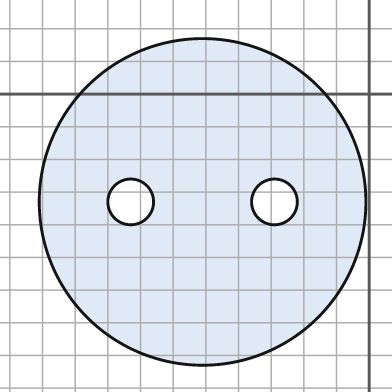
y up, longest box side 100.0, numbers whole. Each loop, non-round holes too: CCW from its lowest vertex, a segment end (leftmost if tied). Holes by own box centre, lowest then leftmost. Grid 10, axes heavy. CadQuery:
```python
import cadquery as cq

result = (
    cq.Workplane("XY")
    .moveTo(-51.0, -33.0)
    .circle(50.0)
    .moveTo(-73.0, -33.0)
    .circle(7.0)
    .moveTo(-29.0, -33.0)
    .circle(7.0)
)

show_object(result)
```